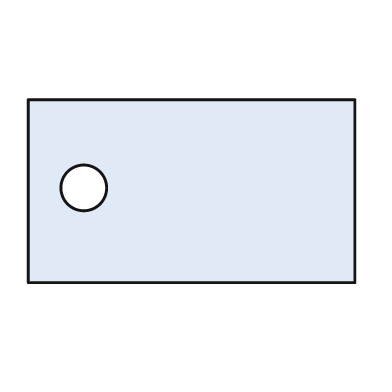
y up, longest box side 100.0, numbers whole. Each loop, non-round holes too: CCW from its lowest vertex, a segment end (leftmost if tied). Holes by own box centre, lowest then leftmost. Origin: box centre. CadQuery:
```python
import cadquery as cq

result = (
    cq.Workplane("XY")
    .moveTo(-50.0, -28.0)
    .lineTo(50.0, -28.0)
    .lineTo(50.0, 28.0)
    .lineTo(-50.0, 28.0)
    .close()
    .moveTo(-33.0, 1.0)
    .circle(7.0)
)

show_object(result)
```